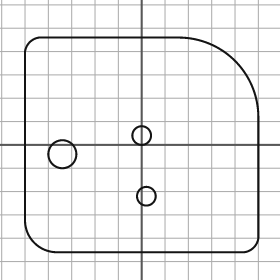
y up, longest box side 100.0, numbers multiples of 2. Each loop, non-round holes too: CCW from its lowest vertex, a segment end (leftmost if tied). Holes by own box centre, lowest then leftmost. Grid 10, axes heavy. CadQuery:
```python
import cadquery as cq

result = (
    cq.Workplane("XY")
    .moveTo(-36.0, -46.0)
    .lineTo(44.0, -46.0)
    .threePointArc((48.0, -44.0), (50.0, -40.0))
    .lineTo(50.0, 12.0)
    .threePointArc((40.0, 36.0), (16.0, 46.0))
    .lineTo(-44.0, 46.0)
    .threePointArc((-48.0, 44.0), (-50.0, 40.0))
    .lineTo(-50.0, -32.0)
    .threePointArc((-46.0, -42.0), (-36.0, -46.0))
    .close()
    .moveTo(2.0, -22.0)
    .circle(4.0)
    .moveTo(-34.0, -4.0)
    .circle(6.0)
    .moveTo(0.0, 4.0)
    .circle(4.0)
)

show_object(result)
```